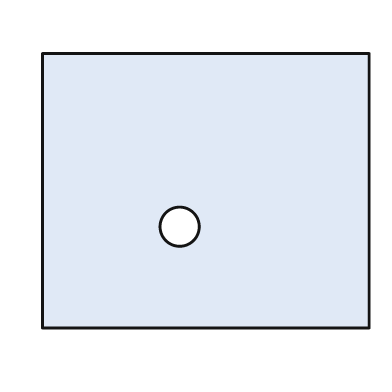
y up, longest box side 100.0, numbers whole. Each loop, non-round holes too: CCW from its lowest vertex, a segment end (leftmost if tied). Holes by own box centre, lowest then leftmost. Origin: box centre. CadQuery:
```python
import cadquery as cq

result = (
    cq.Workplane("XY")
    .moveTo(-50.0, -42.0)
    .lineTo(50.0, -42.0)
    .lineTo(50.0, 42.0)
    .lineTo(-50.0, 42.0)
    .close()
    .moveTo(-8.0, -11.0)
    .circle(6.0)
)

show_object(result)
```